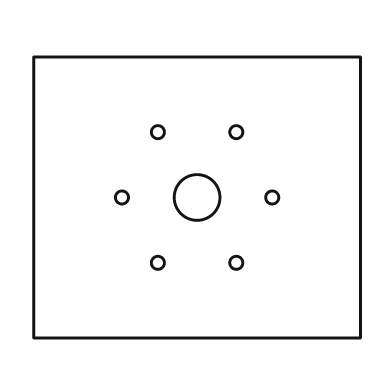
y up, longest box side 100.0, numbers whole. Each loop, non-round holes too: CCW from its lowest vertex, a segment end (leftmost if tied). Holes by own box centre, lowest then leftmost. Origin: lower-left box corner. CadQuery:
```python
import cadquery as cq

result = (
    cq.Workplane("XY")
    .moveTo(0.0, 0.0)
    .lineTo(100.0, 0.0)
    .lineTo(100.0, 86.0)
    .lineTo(0.0, 86.0)
    .close()
    .moveTo(38.0, 23.0)
    .circle(2.0)
    .moveTo(62.0, 23.0)
    .circle(2.0)
    .moveTo(27.0, 43.0)
    .circle(2.0)
    .moveTo(50.0, 43.0)
    .circle(7.0)
    .moveTo(73.0, 43.0)
    .circle(2.0)
    .moveTo(38.0, 63.0)
    .circle(2.0)
    .moveTo(62.0, 63.0)
    .circle(2.0)
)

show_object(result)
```